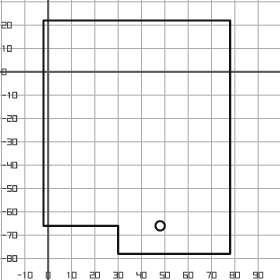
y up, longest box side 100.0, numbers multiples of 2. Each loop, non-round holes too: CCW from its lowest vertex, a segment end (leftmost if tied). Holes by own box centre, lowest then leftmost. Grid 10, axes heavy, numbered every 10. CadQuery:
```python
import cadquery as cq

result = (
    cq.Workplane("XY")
    .moveTo(30.0, -78.0)
    .lineTo(78.0, -78.0)
    .lineTo(78.0, 22.0)
    .lineTo(-2.0, 22.0)
    .lineTo(-2.0, -66.0)
    .lineTo(30.0, -66.0)
    .close()
    .moveTo(48.0, -66.0)
    .circle(2.0)
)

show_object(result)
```